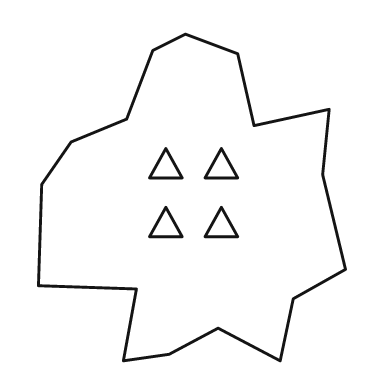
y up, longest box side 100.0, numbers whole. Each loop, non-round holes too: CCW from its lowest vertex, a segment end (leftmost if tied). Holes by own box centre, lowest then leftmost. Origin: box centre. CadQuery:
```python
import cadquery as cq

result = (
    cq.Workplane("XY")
    .moveTo(-21.0, -50.0)
    .lineTo(-7.0, -48.0)
    .lineTo(8.0, -40.0)
    .lineTo(27.0, -50.0)
    .lineTo(31.0, -31.0)
    .lineTo(47.0, -22.0)
    .lineTo(40.0, 7.0)
    .lineTo(42.0, 27.0)
    .lineTo(19.0, 22.0)
    .lineTo(14.0, 44.0)
    .lineTo(-2.0, 50.0)
    .lineTo(-12.0, 45.0)
    .lineTo(-20.0, 24.0)
    .lineTo(-37.0, 17.0)
    .lineTo(-46.0, 4.0)
    .lineTo(-47.0, -27.0)
    .lineTo(-17.0, -28.0)
    .close()
    .moveTo(-13.0, -12.0)
    .lineTo(-3.0, -12.0)
    .lineTo(-8.0, -3.0)
    .close()
    .moveTo(4.0, -12.0)
    .lineTo(14.0, -12.0)
    .lineTo(9.0, -3.0)
    .close()
    .moveTo(-13.0, 6.0)
    .lineTo(-3.0, 6.0)
    .lineTo(-8.0, 15.0)
    .close()
    .moveTo(4.0, 6.0)
    .lineTo(14.0, 6.0)
    .lineTo(9.0, 15.0)
    .close()
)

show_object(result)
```